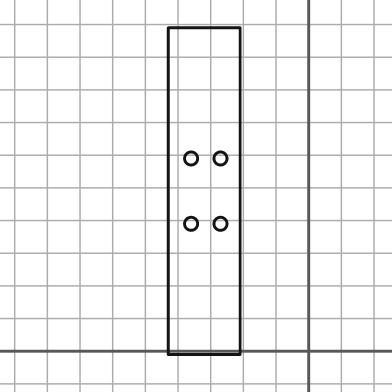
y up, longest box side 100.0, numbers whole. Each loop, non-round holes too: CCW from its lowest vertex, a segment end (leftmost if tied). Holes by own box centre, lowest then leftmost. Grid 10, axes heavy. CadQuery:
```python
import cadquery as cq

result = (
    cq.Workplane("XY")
    .moveTo(-43.0, -1.0)
    .lineTo(-21.0, -1.0)
    .lineTo(-21.0, 99.0)
    .lineTo(-43.0, 99.0)
    .close()
    .moveTo(-36.0, 39.0)
    .circle(2.0)
    .moveTo(-27.0, 39.0)
    .circle(2.0)
    .moveTo(-36.0, 59.0)
    .circle(2.0)
    .moveTo(-27.0, 59.0)
    .circle(2.0)
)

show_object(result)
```